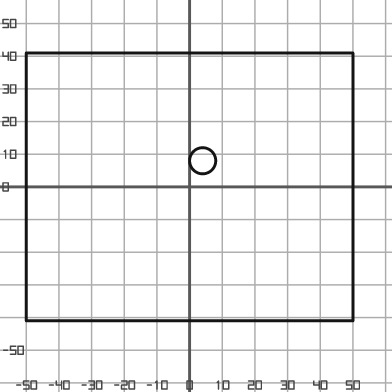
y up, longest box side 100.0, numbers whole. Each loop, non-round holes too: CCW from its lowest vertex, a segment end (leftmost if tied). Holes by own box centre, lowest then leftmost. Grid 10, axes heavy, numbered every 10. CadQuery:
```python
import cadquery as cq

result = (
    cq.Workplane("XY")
    .moveTo(-50.0, -41.0)
    .lineTo(50.0, -41.0)
    .lineTo(50.0, 41.0)
    .lineTo(-50.0, 41.0)
    .close()
    .moveTo(4.0, 8.0)
    .circle(4.0)
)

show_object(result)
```